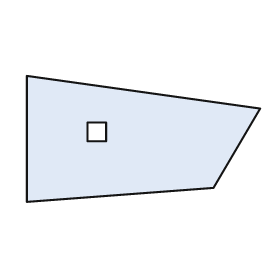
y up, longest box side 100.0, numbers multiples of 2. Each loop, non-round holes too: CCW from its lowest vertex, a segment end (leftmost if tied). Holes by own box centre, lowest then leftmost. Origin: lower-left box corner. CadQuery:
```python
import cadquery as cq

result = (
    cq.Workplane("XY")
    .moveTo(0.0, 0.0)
    .lineTo(80.0, 6.0)
    .lineTo(100.0, 40.0)
    .lineTo(0.0, 54.0)
    .close()
    .moveTo(26.0, 26.0)
    .lineTo(34.0, 26.0)
    .lineTo(34.0, 34.0)
    .lineTo(26.0, 34.0)
    .close()
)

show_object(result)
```